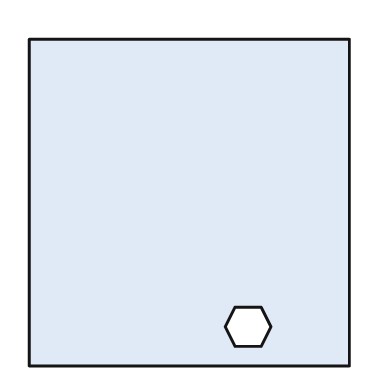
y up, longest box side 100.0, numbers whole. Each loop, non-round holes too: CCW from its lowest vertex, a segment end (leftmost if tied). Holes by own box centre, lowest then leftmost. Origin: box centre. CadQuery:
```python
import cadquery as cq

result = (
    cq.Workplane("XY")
    .moveTo(-49.0, -50.0)
    .lineTo(49.0, -50.0)
    .lineTo(49.0, 50.0)
    .lineTo(-49.0, 50.0)
    .close()
    .moveTo(14.0, -44.0)
    .lineTo(22.0, -44.0)
    .lineTo(25.0, -38.0)
    .lineTo(22.0, -32.0)
    .lineTo(14.0, -32.0)
    .lineTo(11.0, -38.0)
    .close()
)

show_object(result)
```